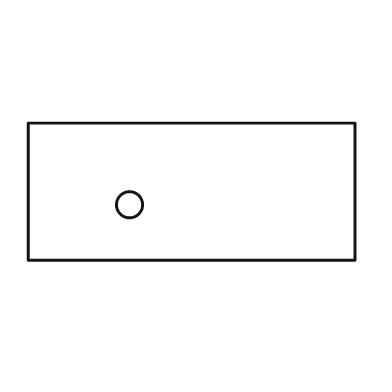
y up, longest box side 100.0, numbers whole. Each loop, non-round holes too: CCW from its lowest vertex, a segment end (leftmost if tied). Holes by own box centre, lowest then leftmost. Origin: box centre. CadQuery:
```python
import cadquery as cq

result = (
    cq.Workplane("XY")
    .moveTo(-50.0, -21.0)
    .lineTo(50.0, -21.0)
    .lineTo(50.0, 21.0)
    .lineTo(-50.0, 21.0)
    .close()
    .moveTo(-19.0, -4.0)
    .circle(4.0)
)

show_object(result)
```